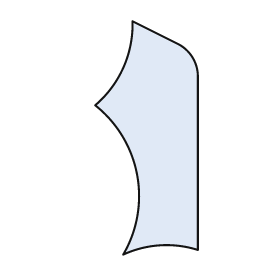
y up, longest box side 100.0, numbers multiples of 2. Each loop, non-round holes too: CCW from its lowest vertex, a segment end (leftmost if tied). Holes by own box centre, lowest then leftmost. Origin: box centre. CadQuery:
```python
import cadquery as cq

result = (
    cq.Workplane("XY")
    .moveTo(-10.0, -50.0)
    .threePointArc((6.0, -46.0), (22.0, -48.0))
    .lineTo(22.0, 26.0)
    .threePointArc((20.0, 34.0), (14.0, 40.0))
    .lineTo(-6.0, 50.0)
    .threePointArc((-10.0, 30.0), (-22.0, 14.0))
    .threePointArc((-4.0, -16.0), (-10.0, -50.0))
    .close()
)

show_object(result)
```